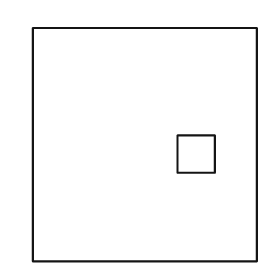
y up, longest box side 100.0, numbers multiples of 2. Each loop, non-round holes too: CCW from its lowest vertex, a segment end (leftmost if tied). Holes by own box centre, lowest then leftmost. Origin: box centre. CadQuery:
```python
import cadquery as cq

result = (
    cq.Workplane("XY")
    .moveTo(-48.0, -50.0)
    .lineTo(48.0, -50.0)
    .lineTo(48.0, 50.0)
    .lineTo(-48.0, 50.0)
    .close()
    .moveTo(14.0, -12.0)
    .lineTo(30.0, -12.0)
    .lineTo(30.0, 4.0)
    .lineTo(14.0, 4.0)
    .close()
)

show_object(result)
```